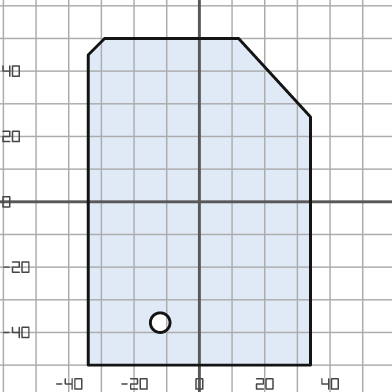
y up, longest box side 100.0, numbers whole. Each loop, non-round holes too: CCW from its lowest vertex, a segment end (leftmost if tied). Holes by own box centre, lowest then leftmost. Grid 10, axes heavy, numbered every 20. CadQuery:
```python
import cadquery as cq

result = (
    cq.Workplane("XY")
    .moveTo(-34.0, -50.0)
    .lineTo(34.0, -50.0)
    .lineTo(34.0, 26.0)
    .lineTo(12.0, 50.0)
    .lineTo(-29.0, 50.0)
    .lineTo(-34.0, 45.0)
    .close()
    .moveTo(-12.0, -37.0)
    .circle(3.0)
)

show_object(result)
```